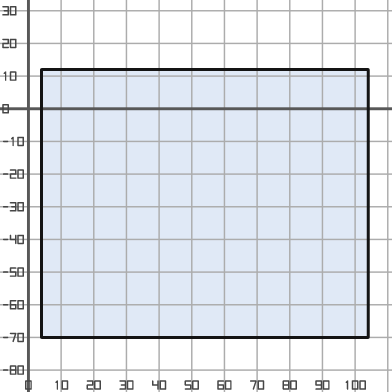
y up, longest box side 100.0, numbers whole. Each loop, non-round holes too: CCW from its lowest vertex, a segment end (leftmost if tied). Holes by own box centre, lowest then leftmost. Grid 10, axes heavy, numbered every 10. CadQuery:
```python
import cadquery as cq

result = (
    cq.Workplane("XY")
    .moveTo(4.0, -70.0)
    .lineTo(104.0, -70.0)
    .lineTo(104.0, 12.0)
    .lineTo(4.0, 12.0)
    .close()
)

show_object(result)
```